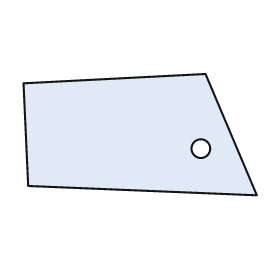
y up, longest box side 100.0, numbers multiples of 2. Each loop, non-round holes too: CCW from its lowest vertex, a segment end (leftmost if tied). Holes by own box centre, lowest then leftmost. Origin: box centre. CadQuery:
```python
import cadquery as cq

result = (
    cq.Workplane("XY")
    .moveTo(50.0, -26.0)
    .lineTo(28.0, 26.0)
    .lineTo(-50.0, 22.0)
    .lineTo(-48.0, -22.0)
    .close()
    .moveTo(26.0, -6.0)
    .circle(4.0)
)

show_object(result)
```